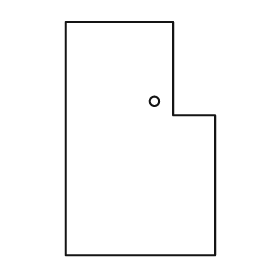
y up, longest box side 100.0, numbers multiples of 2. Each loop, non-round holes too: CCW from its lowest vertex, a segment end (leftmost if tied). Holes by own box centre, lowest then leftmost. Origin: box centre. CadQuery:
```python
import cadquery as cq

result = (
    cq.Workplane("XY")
    .moveTo(-32.0, -50.0)
    .lineTo(32.0, -50.0)
    .lineTo(32.0, 10.0)
    .lineTo(14.0, 10.0)
    .lineTo(14.0, 50.0)
    .lineTo(-32.0, 50.0)
    .close()
    .moveTo(6.0, 16.0)
    .circle(2.0)
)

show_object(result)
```